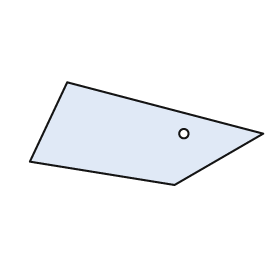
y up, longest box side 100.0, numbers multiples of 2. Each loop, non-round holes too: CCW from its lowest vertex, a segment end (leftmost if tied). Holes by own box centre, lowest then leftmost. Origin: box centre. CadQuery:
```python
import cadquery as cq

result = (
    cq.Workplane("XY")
    .moveTo(12.0, -22.0)
    .lineTo(50.0, 0.0)
    .lineTo(-34.0, 22.0)
    .lineTo(-50.0, -12.0)
    .close()
    .moveTo(16.0, 0.0)
    .circle(2.0)
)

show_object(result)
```